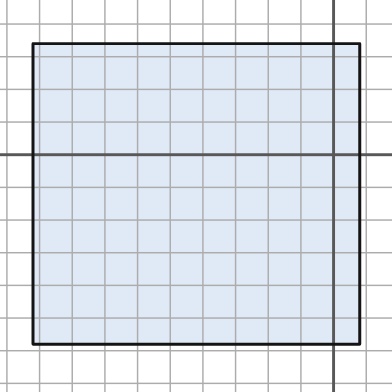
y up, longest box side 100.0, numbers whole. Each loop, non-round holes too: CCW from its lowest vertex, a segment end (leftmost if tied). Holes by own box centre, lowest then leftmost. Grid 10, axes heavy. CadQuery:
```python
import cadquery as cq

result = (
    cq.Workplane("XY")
    .moveTo(-92.0, -58.0)
    .lineTo(8.0, -58.0)
    .lineTo(8.0, 34.0)
    .lineTo(-92.0, 34.0)
    .close()
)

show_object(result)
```